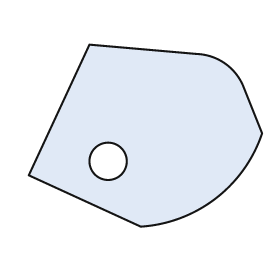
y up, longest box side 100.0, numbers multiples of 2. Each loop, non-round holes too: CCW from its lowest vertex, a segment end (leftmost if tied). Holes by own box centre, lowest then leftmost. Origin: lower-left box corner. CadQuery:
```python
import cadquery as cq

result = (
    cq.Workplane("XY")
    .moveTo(48.0, 0.0)
    .threePointArc((80.0, 12.0), (100.0, 40.0))
    .lineTo(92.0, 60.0)
    .threePointArc((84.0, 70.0), (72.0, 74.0))
    .lineTo(26.0, 78.0)
    .lineTo(0.0, 22.0)
    .close()
    .moveTo(34.0, 28.0)
    .circle(8.0)
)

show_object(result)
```